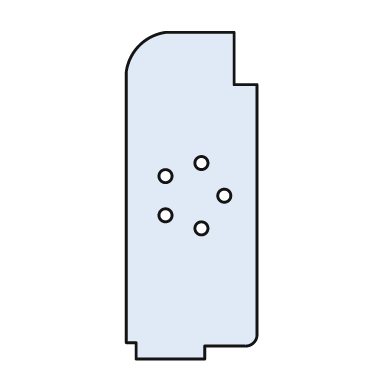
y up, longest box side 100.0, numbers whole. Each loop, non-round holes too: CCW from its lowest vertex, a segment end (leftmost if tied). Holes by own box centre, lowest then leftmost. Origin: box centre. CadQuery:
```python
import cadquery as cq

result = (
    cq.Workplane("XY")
    .moveTo(-17.0, -50.0)
    .lineTo(4.0, -50.0)
    .lineTo(4.0, -46.0)
    .lineTo(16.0, -46.0)
    .threePointArc((19.0, -45.0), (20.0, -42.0))
    .lineTo(20.0, 34.0)
    .lineTo(13.0, 34.0)
    .lineTo(13.0, 50.0)
    .lineTo(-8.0, 50.0)
    .threePointArc((-16.0, 46.0), (-20.0, 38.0))
    .lineTo(-20.0, -45.0)
    .lineTo(-17.0, -45.0)
    .close()
    .moveTo(3.0, -10.0)
    .circle(2.0)
    .moveTo(-8.0, -6.0)
    .circle(2.0)
    .moveTo(10.0, 0.0)
    .circle(2.0)
    .moveTo(-8.0, 6.0)
    .circle(2.0)
    .moveTo(3.0, 10.0)
    .circle(2.0)
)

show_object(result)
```